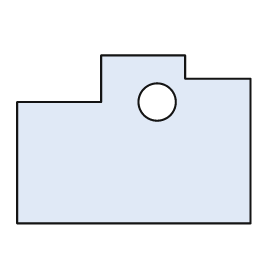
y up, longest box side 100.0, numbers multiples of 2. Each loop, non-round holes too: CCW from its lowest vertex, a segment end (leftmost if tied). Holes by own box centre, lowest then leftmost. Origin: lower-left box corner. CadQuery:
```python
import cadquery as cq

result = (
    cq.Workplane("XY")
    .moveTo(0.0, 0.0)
    .lineTo(100.0, 0.0)
    .lineTo(100.0, 62.0)
    .lineTo(72.0, 62.0)
    .lineTo(72.0, 72.0)
    .lineTo(36.0, 72.0)
    .lineTo(36.0, 52.0)
    .lineTo(0.0, 52.0)
    .close()
    .moveTo(60.0, 52.0)
    .circle(8.0)
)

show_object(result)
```